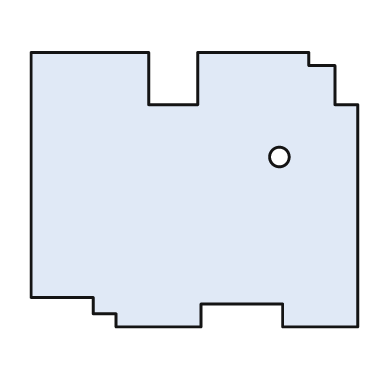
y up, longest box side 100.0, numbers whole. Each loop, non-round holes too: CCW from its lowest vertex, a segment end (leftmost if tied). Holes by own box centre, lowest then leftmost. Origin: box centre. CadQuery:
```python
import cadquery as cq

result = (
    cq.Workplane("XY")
    .moveTo(-24.0, -42.0)
    .lineTo(2.0, -42.0)
    .lineTo(2.0, -35.0)
    .lineTo(27.0, -35.0)
    .lineTo(27.0, -42.0)
    .lineTo(50.0, -42.0)
    .lineTo(50.0, 26.0)
    .lineTo(43.0, 26.0)
    .lineTo(43.0, 38.0)
    .lineTo(35.0, 38.0)
    .lineTo(35.0, 42.0)
    .lineTo(1.0, 42.0)
    .lineTo(1.0, 26.0)
    .lineTo(-14.0, 26.0)
    .lineTo(-14.0, 42.0)
    .lineTo(-50.0, 42.0)
    .lineTo(-50.0, -33.0)
    .lineTo(-31.0, -33.0)
    .lineTo(-31.0, -38.0)
    .lineTo(-24.0, -38.0)
    .close()
    .moveTo(26.0, 10.0)
    .circle(3.0)
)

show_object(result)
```